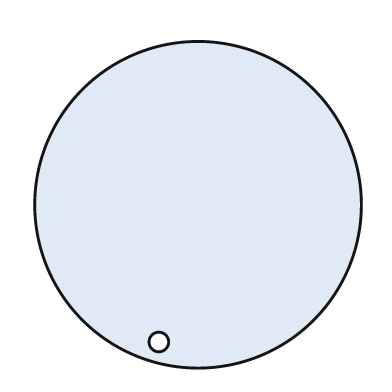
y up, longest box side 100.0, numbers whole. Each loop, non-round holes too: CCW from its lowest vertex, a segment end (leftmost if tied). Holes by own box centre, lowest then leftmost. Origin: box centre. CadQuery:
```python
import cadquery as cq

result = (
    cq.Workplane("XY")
    .moveTo(0.0, 0.0)
    .circle(50.0)
    .moveTo(-12.0, -42.0)
    .circle(3.0)
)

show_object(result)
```